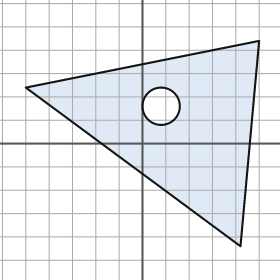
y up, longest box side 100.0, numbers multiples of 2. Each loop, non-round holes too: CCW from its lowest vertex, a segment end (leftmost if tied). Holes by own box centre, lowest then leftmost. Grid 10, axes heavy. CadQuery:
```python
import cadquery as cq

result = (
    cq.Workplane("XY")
    .moveTo(42.0, -44.0)
    .lineTo(50.0, 44.0)
    .lineTo(-50.0, 24.0)
    .close()
    .moveTo(8.0, 16.0)
    .circle(8.0)
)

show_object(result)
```